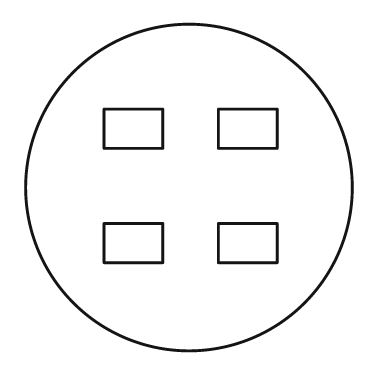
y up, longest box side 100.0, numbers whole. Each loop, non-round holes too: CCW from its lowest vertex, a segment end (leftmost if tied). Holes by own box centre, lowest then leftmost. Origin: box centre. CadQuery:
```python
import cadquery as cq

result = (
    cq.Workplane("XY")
    .moveTo(0.0, 0.0)
    .circle(50.0)
    .moveTo(-26.0, -23.0)
    .lineTo(-8.0, -23.0)
    .lineTo(-8.0, -11.0)
    .lineTo(-26.0, -11.0)
    .close()
    .moveTo(9.0, -23.0)
    .lineTo(27.0, -23.0)
    .lineTo(27.0, -11.0)
    .lineTo(9.0, -11.0)
    .close()
    .moveTo(-26.0, 12.0)
    .lineTo(-8.0, 12.0)
    .lineTo(-8.0, 24.0)
    .lineTo(-26.0, 24.0)
    .close()
    .moveTo(9.0, 12.0)
    .lineTo(27.0, 12.0)
    .lineTo(27.0, 24.0)
    .lineTo(9.0, 24.0)
    .close()
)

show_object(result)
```